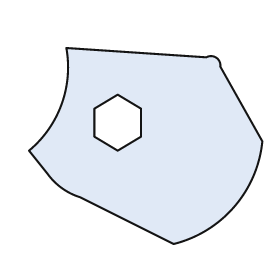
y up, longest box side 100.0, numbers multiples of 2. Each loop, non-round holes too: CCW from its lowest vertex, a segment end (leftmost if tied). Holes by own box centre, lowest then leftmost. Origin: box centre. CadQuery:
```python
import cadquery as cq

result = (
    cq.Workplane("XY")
    .moveTo(12.0, -42.0)
    .threePointArc((38.0, -26.0), (50.0, 2.0))
    .lineTo(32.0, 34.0)
    .threePointArc((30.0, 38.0), (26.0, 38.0))
    .lineTo(-34.0, 42.0)
    .threePointArc((-36.0, 18.0), (-50.0, -2.0))
    .lineTo(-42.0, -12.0)
    .threePointArc((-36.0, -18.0), (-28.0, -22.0))
    .close()
    .moveTo(-12.0, -2.0)
    .lineTo(-2.0, 4.0)
    .lineTo(-2.0, 16.0)
    .lineTo(-12.0, 22.0)
    .lineTo(-22.0, 16.0)
    .lineTo(-22.0, 4.0)
    .close()
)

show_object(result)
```